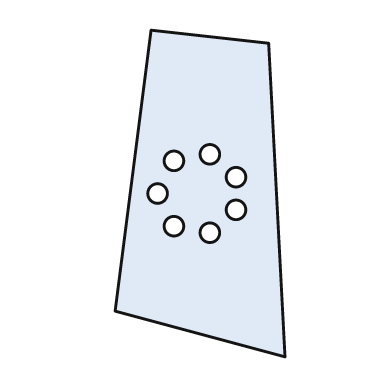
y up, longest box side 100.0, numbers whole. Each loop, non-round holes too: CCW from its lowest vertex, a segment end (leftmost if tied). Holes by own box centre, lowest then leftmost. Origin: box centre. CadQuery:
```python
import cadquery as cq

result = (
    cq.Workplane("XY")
    .moveTo(26.0, -50.0)
    .lineTo(21.0, 46.0)
    .lineTo(-15.0, 50.0)
    .lineTo(-26.0, -36.0)
    .close()
    .moveTo(3.0, -12.0)
    .circle(3.0)
    .moveTo(-8.0, -10.0)
    .circle(3.0)
    .moveTo(11.0, -5.0)
    .circle(3.0)
    .moveTo(-13.0, 0.0)
    .circle(3.0)
    .moveTo(11.0, 5.0)
    .circle(3.0)
    .moveTo(-8.0, 10.0)
    .circle(3.0)
    .moveTo(3.0, 12.0)
    .circle(3.0)
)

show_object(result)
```